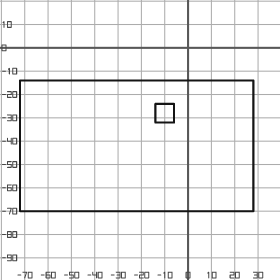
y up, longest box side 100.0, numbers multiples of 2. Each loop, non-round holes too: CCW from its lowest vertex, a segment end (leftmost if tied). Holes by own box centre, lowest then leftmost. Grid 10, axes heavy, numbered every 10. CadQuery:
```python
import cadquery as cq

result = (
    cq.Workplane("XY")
    .moveTo(-72.0, -70.0)
    .lineTo(28.0, -70.0)
    .lineTo(28.0, -14.0)
    .lineTo(-72.0, -14.0)
    .close()
    .moveTo(-14.0, -32.0)
    .lineTo(-6.0, -32.0)
    .lineTo(-6.0, -24.0)
    .lineTo(-14.0, -24.0)
    .close()
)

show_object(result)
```